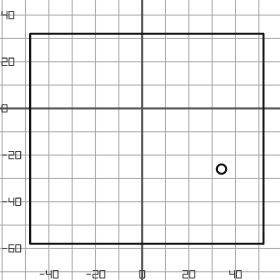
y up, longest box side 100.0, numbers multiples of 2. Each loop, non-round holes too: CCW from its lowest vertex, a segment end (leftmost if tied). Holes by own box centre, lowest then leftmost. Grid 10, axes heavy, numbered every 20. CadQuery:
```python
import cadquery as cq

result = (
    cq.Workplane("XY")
    .moveTo(-48.0, -58.0)
    .lineTo(52.0, -58.0)
    .lineTo(52.0, 32.0)
    .lineTo(-48.0, 32.0)
    .close()
    .moveTo(34.0, -26.0)
    .circle(2.0)
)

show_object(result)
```